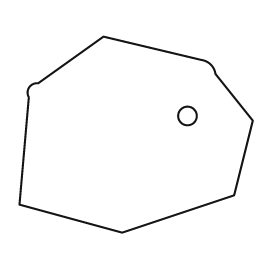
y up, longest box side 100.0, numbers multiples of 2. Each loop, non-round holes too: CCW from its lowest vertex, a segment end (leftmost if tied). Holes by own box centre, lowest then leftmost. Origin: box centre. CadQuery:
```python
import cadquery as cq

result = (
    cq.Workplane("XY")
    .moveTo(-6.0, -42.0)
    .lineTo(42.0, -26.0)
    .lineTo(50.0, 6.0)
    .lineTo(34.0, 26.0)
    .threePointArc((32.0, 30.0), (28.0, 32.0))
    .lineTo(-14.0, 42.0)
    .lineTo(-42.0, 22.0)
    .threePointArc((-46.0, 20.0), (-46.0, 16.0))
    .lineTo(-50.0, -30.0)
    .close()
    .moveTo(22.0, 8.0)
    .circle(4.0)
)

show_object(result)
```